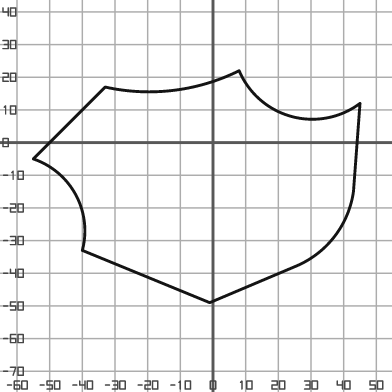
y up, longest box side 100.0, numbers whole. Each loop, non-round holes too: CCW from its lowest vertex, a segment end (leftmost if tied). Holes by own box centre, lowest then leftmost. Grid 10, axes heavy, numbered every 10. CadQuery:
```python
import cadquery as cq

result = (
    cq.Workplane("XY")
    .moveTo(-1.0, -49.0)
    .lineTo(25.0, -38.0)
    .threePointArc((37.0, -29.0), (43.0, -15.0))
    .lineTo(45.0, 12.0)
    .threePointArc((24.0, 8.0), (8.0, 22.0))
    .threePointArc((-12.0, 16.0), (-33.0, 17.0))
    .lineTo(-55.0, -5.0)
    .threePointArc((-42.0, -16.0), (-40.0, -33.0))
    .close()
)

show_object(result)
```